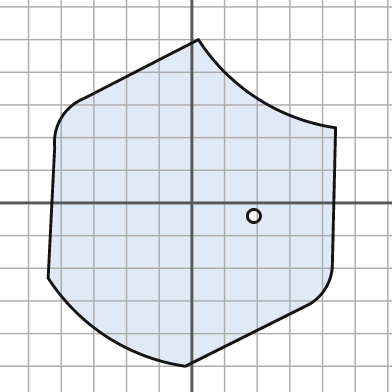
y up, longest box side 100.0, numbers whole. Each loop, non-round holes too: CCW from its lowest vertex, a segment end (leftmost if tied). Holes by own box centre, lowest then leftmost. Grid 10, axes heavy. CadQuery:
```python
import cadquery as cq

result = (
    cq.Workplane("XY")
    .moveTo(-2.0, -50.0)
    .lineTo(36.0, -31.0)
    .threePointArc((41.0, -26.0), (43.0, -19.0))
    .lineTo(44.0, 23.0)
    .threePointArc((20.0, 32.0), (2.0, 50.0))
    .lineTo(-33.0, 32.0)
    .threePointArc((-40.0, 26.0), (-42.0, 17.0))
    .lineTo(-44.0, -23.0)
    .threePointArc((-26.0, -41.0), (-2.0, -50.0))
    .close()
    .moveTo(19.0, -4.0)
    .circle(2.0)
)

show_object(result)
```